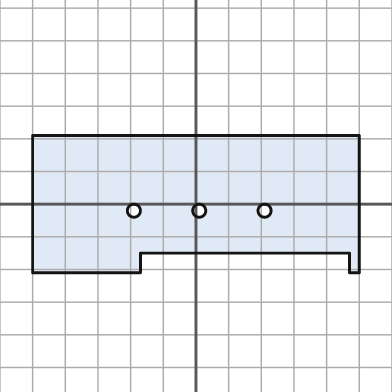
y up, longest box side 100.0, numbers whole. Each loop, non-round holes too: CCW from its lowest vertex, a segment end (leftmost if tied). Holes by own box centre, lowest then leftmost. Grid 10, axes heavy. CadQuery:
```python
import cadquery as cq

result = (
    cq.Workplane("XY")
    .moveTo(-50.0, -21.0)
    .lineTo(-17.0, -21.0)
    .lineTo(-17.0, -15.0)
    .lineTo(47.0, -15.0)
    .lineTo(47.0, -21.0)
    .lineTo(50.0, -21.0)
    .lineTo(50.0, 21.0)
    .lineTo(-50.0, 21.0)
    .close()
    .moveTo(-19.0, -2.0)
    .circle(2.0)
    .moveTo(1.0, -2.0)
    .circle(2.0)
    .moveTo(21.0, -2.0)
    .circle(2.0)
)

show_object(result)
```